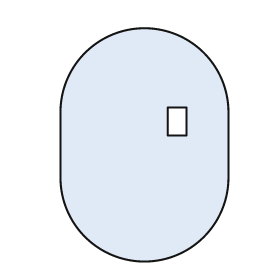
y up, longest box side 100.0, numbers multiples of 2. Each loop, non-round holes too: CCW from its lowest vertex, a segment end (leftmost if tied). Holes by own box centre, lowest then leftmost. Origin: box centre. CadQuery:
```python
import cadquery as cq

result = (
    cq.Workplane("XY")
    .moveTo(-36.0, -14.0)
    .threePointArc((0.0, -50.0), (36.0, -14.0))
    .lineTo(36.0, 14.0)
    .threePointArc((0.0, 50.0), (-36.0, 14.0))
    .close()
    .moveTo(10.0, 4.0)
    .lineTo(18.0, 4.0)
    .lineTo(18.0, 16.0)
    .lineTo(10.0, 16.0)
    .close()
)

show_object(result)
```